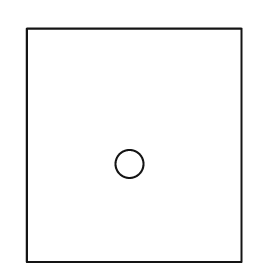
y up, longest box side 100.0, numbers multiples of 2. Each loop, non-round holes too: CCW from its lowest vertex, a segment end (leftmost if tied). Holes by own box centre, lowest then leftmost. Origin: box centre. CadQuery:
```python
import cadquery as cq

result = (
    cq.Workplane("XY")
    .moveTo(-46.0, -50.0)
    .lineTo(46.0, -50.0)
    .lineTo(46.0, 50.0)
    .lineTo(-46.0, 50.0)
    .close()
    .moveTo(-2.0, -8.0)
    .circle(6.0)
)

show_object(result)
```